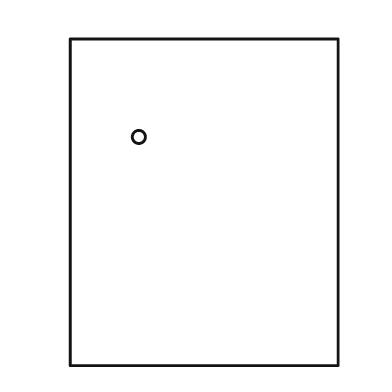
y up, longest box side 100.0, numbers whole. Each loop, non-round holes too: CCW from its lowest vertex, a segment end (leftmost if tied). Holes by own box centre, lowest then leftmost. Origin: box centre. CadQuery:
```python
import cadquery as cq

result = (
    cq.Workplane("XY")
    .moveTo(-41.0, -50.0)
    .lineTo(41.0, -50.0)
    .lineTo(41.0, 50.0)
    .lineTo(-41.0, 50.0)
    .close()
    .moveTo(-20.0, 20.0)
    .circle(2.0)
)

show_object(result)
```